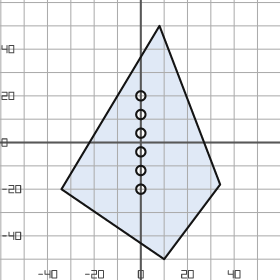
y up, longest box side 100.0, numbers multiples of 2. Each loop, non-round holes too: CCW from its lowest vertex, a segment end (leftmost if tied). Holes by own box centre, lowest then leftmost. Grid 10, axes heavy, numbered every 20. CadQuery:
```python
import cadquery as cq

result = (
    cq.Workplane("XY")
    .moveTo(10.0, -50.0)
    .lineTo(34.0, -18.0)
    .lineTo(8.0, 50.0)
    .lineTo(-34.0, -20.0)
    .close()
    .moveTo(0.0, -20.0)
    .circle(2.0)
    .moveTo(0.0, -12.0)
    .circle(2.0)
    .moveTo(0.0, -4.0)
    .circle(2.0)
    .moveTo(0.0, 4.0)
    .circle(2.0)
    .moveTo(0.0, 12.0)
    .circle(2.0)
    .moveTo(0.0, 20.0)
    .circle(2.0)
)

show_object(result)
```